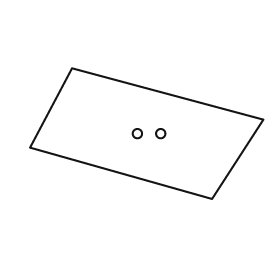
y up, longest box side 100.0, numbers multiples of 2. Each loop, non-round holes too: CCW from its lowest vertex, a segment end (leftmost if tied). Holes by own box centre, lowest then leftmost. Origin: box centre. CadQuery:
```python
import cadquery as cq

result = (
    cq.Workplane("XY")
    .moveTo(28.0, -28.0)
    .lineTo(50.0, 6.0)
    .lineTo(-32.0, 28.0)
    .lineTo(-50.0, -6.0)
    .close()
    .moveTo(-4.0, 0.0)
    .circle(2.0)
    .moveTo(6.0, 0.0)
    .circle(2.0)
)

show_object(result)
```